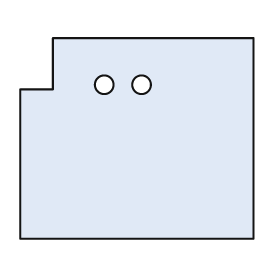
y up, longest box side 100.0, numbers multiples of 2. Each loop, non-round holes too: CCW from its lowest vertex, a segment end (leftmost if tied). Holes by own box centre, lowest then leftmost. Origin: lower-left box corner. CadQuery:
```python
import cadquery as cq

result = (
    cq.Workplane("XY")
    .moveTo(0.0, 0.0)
    .lineTo(100.0, 0.0)
    .lineTo(100.0, 86.0)
    .lineTo(14.0, 86.0)
    .lineTo(14.0, 64.0)
    .lineTo(0.0, 64.0)
    .close()
    .moveTo(36.0, 66.0)
    .circle(4.0)
    .moveTo(52.0, 66.0)
    .circle(4.0)
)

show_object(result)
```